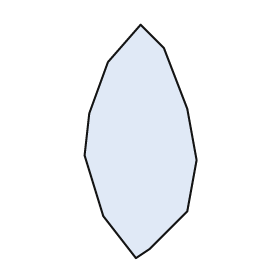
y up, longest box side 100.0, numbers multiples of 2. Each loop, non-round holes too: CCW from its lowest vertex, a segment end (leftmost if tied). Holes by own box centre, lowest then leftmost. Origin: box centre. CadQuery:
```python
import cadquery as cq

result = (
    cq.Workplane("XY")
    .moveTo(-2.0, -50.0)
    .lineTo(4.0, -46.0)
    .lineTo(20.0, -30.0)
    .lineTo(24.0, -8.0)
    .lineTo(20.0, 14.0)
    .lineTo(10.0, 40.0)
    .lineTo(0.0, 50.0)
    .lineTo(-14.0, 34.0)
    .lineTo(-22.0, 12.0)
    .lineTo(-24.0, -6.0)
    .lineTo(-16.0, -32.0)
    .close()
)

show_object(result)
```